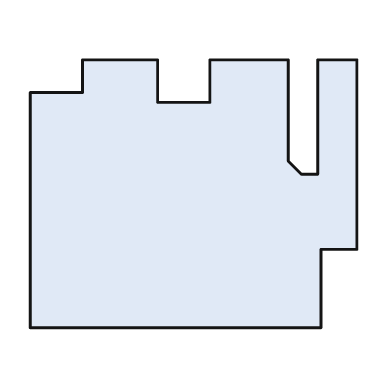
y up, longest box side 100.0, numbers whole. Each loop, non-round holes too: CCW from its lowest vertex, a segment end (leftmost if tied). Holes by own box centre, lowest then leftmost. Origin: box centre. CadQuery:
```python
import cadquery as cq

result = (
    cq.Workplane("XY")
    .moveTo(-50.0, -41.0)
    .lineTo(39.0, -41.0)
    .lineTo(39.0, -17.0)
    .lineTo(50.0, -17.0)
    .lineTo(50.0, 41.0)
    .lineTo(38.0, 41.0)
    .lineTo(38.0, 6.0)
    .lineTo(33.0, 6.0)
    .lineTo(29.0, 10.0)
    .lineTo(29.0, 41.0)
    .lineTo(5.0, 41.0)
    .lineTo(5.0, 28.0)
    .lineTo(-11.0, 28.0)
    .lineTo(-11.0, 41.0)
    .lineTo(-34.0, 41.0)
    .lineTo(-34.0, 31.0)
    .lineTo(-50.0, 31.0)
    .close()
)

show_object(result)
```